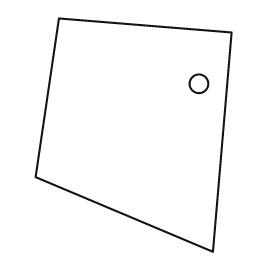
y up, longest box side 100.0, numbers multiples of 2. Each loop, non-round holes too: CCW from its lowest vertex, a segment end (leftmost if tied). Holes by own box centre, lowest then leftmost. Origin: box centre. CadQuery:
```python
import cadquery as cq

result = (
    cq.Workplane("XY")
    .moveTo(34.0, -50.0)
    .lineTo(42.0, 44.0)
    .lineTo(-32.0, 50.0)
    .lineTo(-42.0, -18.0)
    .close()
    .moveTo(28.0, 22.0)
    .circle(4.0)
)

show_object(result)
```